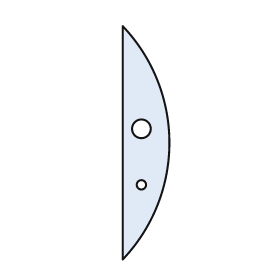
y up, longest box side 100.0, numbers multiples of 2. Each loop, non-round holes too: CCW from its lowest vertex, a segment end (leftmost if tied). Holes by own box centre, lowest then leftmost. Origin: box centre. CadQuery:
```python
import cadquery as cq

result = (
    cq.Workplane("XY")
    .moveTo(-10.0, -50.0)
    .threePointArc((10.0, 0.0), (-10.0, 50.0))
    .close()
    .moveTo(-2.0, -18.0)
    .circle(2.0)
    .moveTo(-2.0, 6.0)
    .circle(4.0)
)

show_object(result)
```